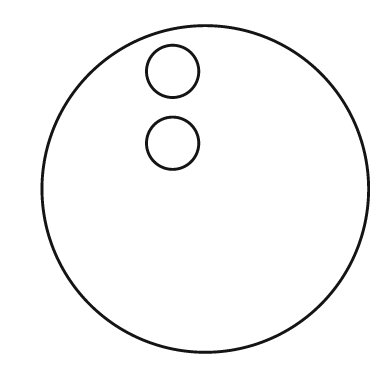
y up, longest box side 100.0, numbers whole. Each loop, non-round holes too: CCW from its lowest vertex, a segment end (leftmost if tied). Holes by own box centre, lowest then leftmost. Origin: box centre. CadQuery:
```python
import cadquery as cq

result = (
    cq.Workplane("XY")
    .moveTo(0.0, 0.0)
    .circle(50.0)
    .moveTo(-10.0, 14.0)
    .circle(8.0)
    .moveTo(-10.0, 36.0)
    .circle(8.0)
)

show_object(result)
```